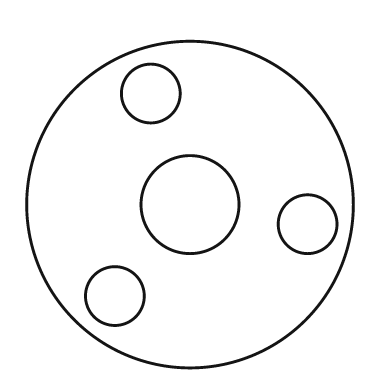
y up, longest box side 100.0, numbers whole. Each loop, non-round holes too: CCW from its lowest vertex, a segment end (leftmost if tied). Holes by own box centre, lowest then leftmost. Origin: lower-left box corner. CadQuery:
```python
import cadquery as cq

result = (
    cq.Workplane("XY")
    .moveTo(50.0, 50.0)
    .circle(50.0)
    .moveTo(27.0, 22.0)
    .circle(9.0)
    .moveTo(86.0, 44.0)
    .circle(9.0)
    .moveTo(50.0, 50.0)
    .circle(15.0)
    .moveTo(38.0, 84.0)
    .circle(9.0)
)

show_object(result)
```